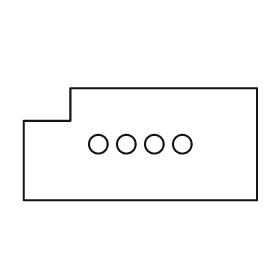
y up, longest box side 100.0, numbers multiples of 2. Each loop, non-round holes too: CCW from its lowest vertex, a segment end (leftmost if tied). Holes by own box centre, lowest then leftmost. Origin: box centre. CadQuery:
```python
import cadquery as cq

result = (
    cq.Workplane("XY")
    .moveTo(-50.0, -24.0)
    .lineTo(50.0, -24.0)
    .lineTo(50.0, 24.0)
    .lineTo(-30.0, 24.0)
    .lineTo(-30.0, 10.0)
    .lineTo(-50.0, 10.0)
    .close()
    .moveTo(-18.0, 0.0)
    .circle(4.0)
    .moveTo(-6.0, 0.0)
    .circle(4.0)
    .moveTo(6.0, 0.0)
    .circle(4.0)
    .moveTo(18.0, 0.0)
    .circle(4.0)
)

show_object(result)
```